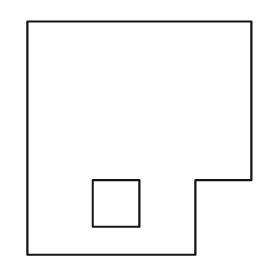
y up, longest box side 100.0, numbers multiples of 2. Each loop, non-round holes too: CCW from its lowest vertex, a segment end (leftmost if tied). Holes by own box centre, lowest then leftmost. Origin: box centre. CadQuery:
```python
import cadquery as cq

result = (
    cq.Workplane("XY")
    .moveTo(-48.0, -50.0)
    .lineTo(24.0, -50.0)
    .lineTo(24.0, -18.0)
    .lineTo(48.0, -18.0)
    .lineTo(48.0, 50.0)
    .lineTo(-48.0, 50.0)
    .close()
    .moveTo(-20.0, -38.0)
    .lineTo(0.0, -38.0)
    .lineTo(0.0, -18.0)
    .lineTo(-20.0, -18.0)
    .close()
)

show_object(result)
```